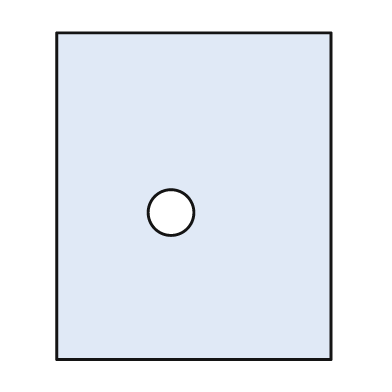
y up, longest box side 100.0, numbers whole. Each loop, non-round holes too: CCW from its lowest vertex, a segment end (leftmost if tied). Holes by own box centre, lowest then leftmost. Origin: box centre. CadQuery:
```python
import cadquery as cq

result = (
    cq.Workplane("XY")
    .moveTo(-42.0, -50.0)
    .lineTo(42.0, -50.0)
    .lineTo(42.0, 50.0)
    .lineTo(-42.0, 50.0)
    .close()
    .moveTo(-7.0, -5.0)
    .circle(7.0)
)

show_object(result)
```